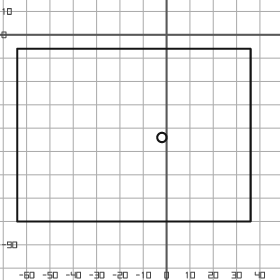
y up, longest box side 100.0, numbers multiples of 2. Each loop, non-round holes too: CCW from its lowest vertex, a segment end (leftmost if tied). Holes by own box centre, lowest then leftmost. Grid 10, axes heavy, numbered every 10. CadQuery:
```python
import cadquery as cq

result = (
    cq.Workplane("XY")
    .moveTo(-64.0, -80.0)
    .lineTo(36.0, -80.0)
    .lineTo(36.0, -6.0)
    .lineTo(-64.0, -6.0)
    .close()
    .moveTo(-2.0, -44.0)
    .circle(2.0)
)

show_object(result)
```